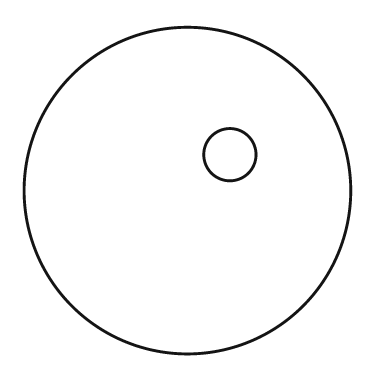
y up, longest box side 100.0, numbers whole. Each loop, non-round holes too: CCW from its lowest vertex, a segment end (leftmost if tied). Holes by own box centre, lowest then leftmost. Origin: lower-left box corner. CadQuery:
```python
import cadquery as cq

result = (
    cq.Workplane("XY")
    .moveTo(50.0, 50.0)
    .circle(50.0)
    .moveTo(63.0, 61.0)
    .circle(8.0)
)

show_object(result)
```